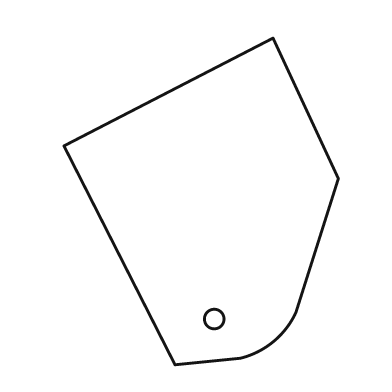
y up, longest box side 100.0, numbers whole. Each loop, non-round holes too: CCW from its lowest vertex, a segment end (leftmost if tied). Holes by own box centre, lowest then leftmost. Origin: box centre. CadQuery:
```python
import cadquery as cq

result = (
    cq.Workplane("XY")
    .moveTo(-8.0, -50.0)
    .lineTo(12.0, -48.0)
    .threePointArc((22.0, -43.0), (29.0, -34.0))
    .lineTo(42.0, 7.0)
    .lineTo(22.0, 50.0)
    .lineTo(-42.0, 17.0)
    .close()
    .moveTo(4.0, -36.0)
    .circle(3.0)
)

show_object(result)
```